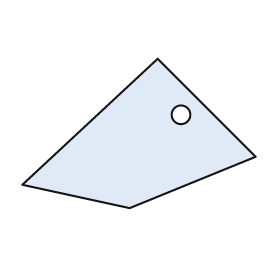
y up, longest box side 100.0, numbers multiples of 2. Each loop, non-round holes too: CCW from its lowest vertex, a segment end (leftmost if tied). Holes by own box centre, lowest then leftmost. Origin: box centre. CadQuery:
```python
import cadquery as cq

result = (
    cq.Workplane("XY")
    .moveTo(-4.0, -32.0)
    .lineTo(50.0, -10.0)
    .lineTo(8.0, 32.0)
    .lineTo(-50.0, -22.0)
    .close()
    .moveTo(18.0, 8.0)
    .circle(4.0)
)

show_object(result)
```